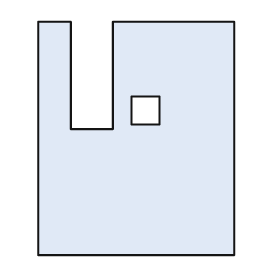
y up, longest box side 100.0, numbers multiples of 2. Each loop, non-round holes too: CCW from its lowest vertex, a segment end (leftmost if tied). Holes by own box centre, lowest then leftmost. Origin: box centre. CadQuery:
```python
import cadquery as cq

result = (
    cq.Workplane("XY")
    .moveTo(-42.0, -50.0)
    .lineTo(42.0, -50.0)
    .lineTo(42.0, 50.0)
    .lineTo(-10.0, 50.0)
    .lineTo(-10.0, 4.0)
    .lineTo(-28.0, 4.0)
    .lineTo(-28.0, 50.0)
    .lineTo(-42.0, 50.0)
    .close()
    .moveTo(-2.0, 6.0)
    .lineTo(10.0, 6.0)
    .lineTo(10.0, 18.0)
    .lineTo(-2.0, 18.0)
    .close()
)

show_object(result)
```